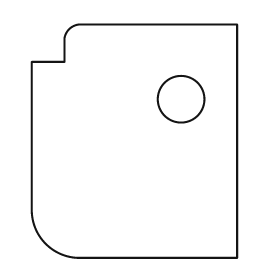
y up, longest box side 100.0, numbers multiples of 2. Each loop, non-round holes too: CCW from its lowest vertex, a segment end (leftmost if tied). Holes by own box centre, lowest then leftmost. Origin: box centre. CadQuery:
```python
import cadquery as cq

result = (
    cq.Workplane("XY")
    .moveTo(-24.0, -50.0)
    .lineTo(44.0, -50.0)
    .lineTo(44.0, 50.0)
    .lineTo(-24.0, 50.0)
    .threePointArc((-28.0, 48.0), (-30.0, 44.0))
    .lineTo(-30.0, 34.0)
    .lineTo(-44.0, 34.0)
    .lineTo(-44.0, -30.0)
    .threePointArc((-38.0, -44.0), (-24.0, -50.0))
    .close()
    .moveTo(20.0, 18.0)
    .circle(10.0)
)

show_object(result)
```